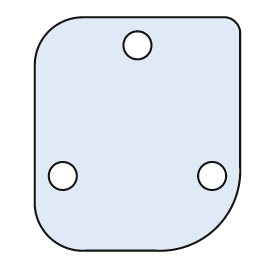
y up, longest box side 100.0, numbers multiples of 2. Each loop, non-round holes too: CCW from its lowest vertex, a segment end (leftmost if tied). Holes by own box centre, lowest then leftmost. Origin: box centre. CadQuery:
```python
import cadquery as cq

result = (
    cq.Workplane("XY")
    .moveTo(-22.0, -50.0)
    .lineTo(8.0, -50.0)
    .threePointArc((34.0, -40.0), (44.0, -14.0))
    .lineTo(44.0, 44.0)
    .threePointArc((42.0, 48.0), (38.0, 50.0))
    .lineTo(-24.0, 50.0)
    .threePointArc((-38.0, 44.0), (-44.0, 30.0))
    .lineTo(-44.0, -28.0)
    .threePointArc((-38.0, -44.0), (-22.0, -50.0))
    .close()
    .moveTo(-32.0, -18.0)
    .circle(6.0)
    .moveTo(32.0, -18.0)
    .circle(6.0)
    .moveTo(0.0, 38.0)
    .circle(6.0)
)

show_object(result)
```